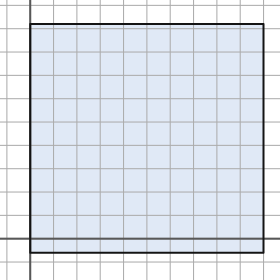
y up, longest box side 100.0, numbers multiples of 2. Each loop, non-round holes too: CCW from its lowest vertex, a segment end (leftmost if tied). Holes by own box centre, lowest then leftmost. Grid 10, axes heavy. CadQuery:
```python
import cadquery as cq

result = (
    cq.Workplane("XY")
    .moveTo(0.0, -6.0)
    .lineTo(100.0, -6.0)
    .lineTo(100.0, 92.0)
    .lineTo(0.0, 92.0)
    .close()
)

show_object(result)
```